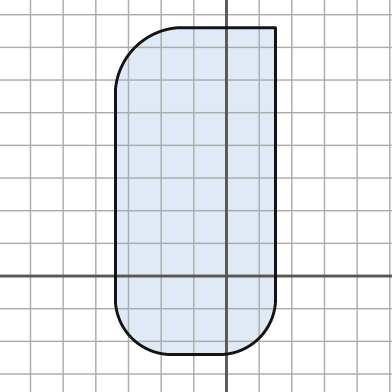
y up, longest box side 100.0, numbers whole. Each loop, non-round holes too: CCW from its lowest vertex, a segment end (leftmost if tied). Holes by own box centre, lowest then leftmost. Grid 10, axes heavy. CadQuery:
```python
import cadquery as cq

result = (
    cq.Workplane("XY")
    .moveTo(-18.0, -24.0)
    .lineTo(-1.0, -24.0)
    .threePointArc((10.0, -19.0), (15.0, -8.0))
    .lineTo(15.0, 76.0)
    .lineTo(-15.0, 76.0)
    .threePointArc((-28.0, 70.0), (-34.0, 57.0))
    .lineTo(-34.0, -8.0)
    .threePointArc((-29.0, -19.0), (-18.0, -24.0))
    .close()
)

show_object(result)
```